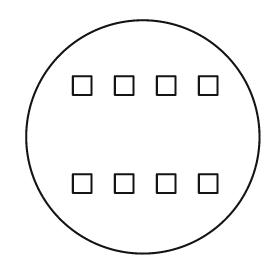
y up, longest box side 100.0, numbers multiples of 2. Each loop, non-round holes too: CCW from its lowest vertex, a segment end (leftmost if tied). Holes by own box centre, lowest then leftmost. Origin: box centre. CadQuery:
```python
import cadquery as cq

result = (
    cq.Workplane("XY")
    .moveTo(0.0, 0.0)
    .circle(50.0)
    .moveTo(-30.0, -24.0)
    .lineTo(-22.0, -24.0)
    .lineTo(-22.0, -16.0)
    .lineTo(-30.0, -16.0)
    .close()
    .moveTo(-12.0, -24.0)
    .lineTo(-4.0, -24.0)
    .lineTo(-4.0, -16.0)
    .lineTo(-12.0, -16.0)
    .close()
    .moveTo(6.0, -24.0)
    .lineTo(14.0, -24.0)
    .lineTo(14.0, -16.0)
    .lineTo(6.0, -16.0)
    .close()
    .moveTo(24.0, -24.0)
    .lineTo(32.0, -24.0)
    .lineTo(32.0, -16.0)
    .lineTo(24.0, -16.0)
    .close()
    .moveTo(-30.0, 18.0)
    .lineTo(-22.0, 18.0)
    .lineTo(-22.0, 26.0)
    .lineTo(-30.0, 26.0)
    .close()
    .moveTo(-12.0, 18.0)
    .lineTo(-4.0, 18.0)
    .lineTo(-4.0, 26.0)
    .lineTo(-12.0, 26.0)
    .close()
    .moveTo(6.0, 18.0)
    .lineTo(14.0, 18.0)
    .lineTo(14.0, 26.0)
    .lineTo(6.0, 26.0)
    .close()
    .moveTo(24.0, 18.0)
    .lineTo(32.0, 18.0)
    .lineTo(32.0, 26.0)
    .lineTo(24.0, 26.0)
    .close()
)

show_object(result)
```